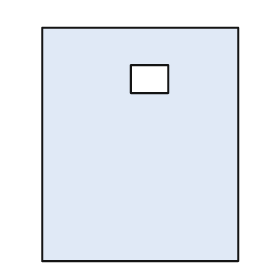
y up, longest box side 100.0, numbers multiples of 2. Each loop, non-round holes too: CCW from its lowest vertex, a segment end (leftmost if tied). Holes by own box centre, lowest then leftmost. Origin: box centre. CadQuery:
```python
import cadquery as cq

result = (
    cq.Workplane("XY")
    .moveTo(-42.0, -50.0)
    .lineTo(42.0, -50.0)
    .lineTo(42.0, 50.0)
    .lineTo(-42.0, 50.0)
    .close()
    .moveTo(-4.0, 22.0)
    .lineTo(12.0, 22.0)
    .lineTo(12.0, 34.0)
    .lineTo(-4.0, 34.0)
    .close()
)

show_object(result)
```